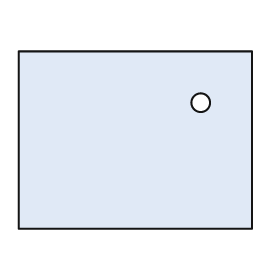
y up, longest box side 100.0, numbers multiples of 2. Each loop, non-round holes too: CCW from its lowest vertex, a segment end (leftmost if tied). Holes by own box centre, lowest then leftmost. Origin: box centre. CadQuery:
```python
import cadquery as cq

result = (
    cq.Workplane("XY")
    .moveTo(-50.0, -38.0)
    .lineTo(50.0, -38.0)
    .lineTo(50.0, 38.0)
    .lineTo(-50.0, 38.0)
    .close()
    .moveTo(28.0, 16.0)
    .circle(4.0)
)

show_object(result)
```